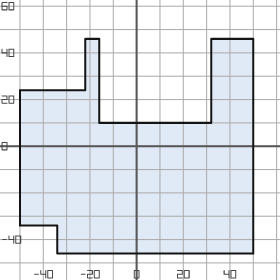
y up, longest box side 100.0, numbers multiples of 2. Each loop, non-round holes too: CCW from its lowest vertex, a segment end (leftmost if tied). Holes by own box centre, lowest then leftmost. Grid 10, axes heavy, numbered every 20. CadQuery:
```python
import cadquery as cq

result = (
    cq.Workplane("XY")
    .moveTo(-34.0, -46.0)
    .lineTo(50.0, -46.0)
    .lineTo(50.0, 46.0)
    .lineTo(32.0, 46.0)
    .lineTo(32.0, 10.0)
    .lineTo(-16.0, 10.0)
    .lineTo(-16.0, 46.0)
    .lineTo(-22.0, 46.0)
    .lineTo(-22.0, 24.0)
    .lineTo(-50.0, 24.0)
    .lineTo(-50.0, -34.0)
    .lineTo(-34.0, -34.0)
    .close()
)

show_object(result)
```